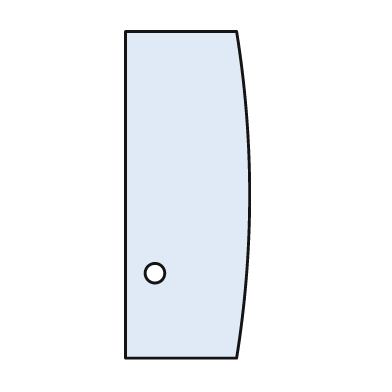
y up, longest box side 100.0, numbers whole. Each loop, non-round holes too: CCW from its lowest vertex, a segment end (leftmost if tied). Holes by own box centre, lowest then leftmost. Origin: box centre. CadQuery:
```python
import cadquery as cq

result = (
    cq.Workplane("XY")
    .moveTo(-19.0, -50.0)
    .lineTo(15.0, -50.0)
    .threePointArc((19.0, 0.0), (15.0, 50.0))
    .lineTo(-19.0, 50.0)
    .close()
    .moveTo(-10.0, -24.0)
    .circle(3.0)
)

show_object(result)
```